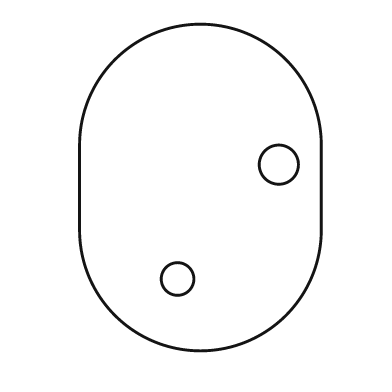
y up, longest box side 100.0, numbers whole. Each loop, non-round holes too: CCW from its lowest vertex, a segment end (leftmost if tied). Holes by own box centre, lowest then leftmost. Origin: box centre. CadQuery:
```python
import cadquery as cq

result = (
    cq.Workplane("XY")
    .moveTo(-37.0, -13.0)
    .threePointArc((0.0, -50.0), (37.0, -13.0))
    .lineTo(37.0, 13.0)
    .threePointArc((0.0, 50.0), (-37.0, 13.0))
    .close()
    .moveTo(-7.0, -28.0)
    .circle(5.0)
    .moveTo(24.0, 7.0)
    .circle(6.0)
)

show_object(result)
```